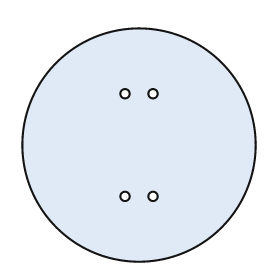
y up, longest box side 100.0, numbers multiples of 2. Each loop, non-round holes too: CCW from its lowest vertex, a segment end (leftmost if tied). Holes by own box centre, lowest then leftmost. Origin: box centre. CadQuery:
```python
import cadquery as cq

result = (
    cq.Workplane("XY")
    .moveTo(0.0, 0.0)
    .circle(50.0)
    .moveTo(-6.0, -22.0)
    .circle(2.0)
    .moveTo(6.0, -22.0)
    .circle(2.0)
    .moveTo(-6.0, 22.0)
    .circle(2.0)
    .moveTo(6.0, 22.0)
    .circle(2.0)
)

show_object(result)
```